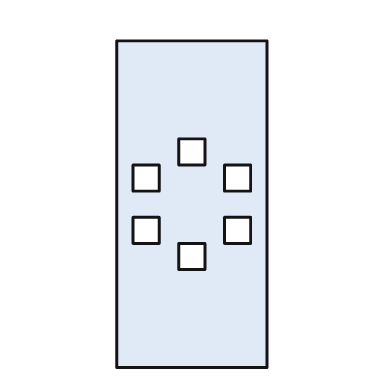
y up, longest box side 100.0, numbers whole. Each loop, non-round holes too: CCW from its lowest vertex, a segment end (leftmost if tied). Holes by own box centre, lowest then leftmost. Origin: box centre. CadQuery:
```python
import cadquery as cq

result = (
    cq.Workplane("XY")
    .moveTo(-23.0, -50.0)
    .lineTo(23.0, -50.0)
    .lineTo(23.0, 50.0)
    .lineTo(-23.0, 50.0)
    .close()
    .moveTo(-4.0, -20.0)
    .lineTo(4.0, -20.0)
    .lineTo(4.0, -12.0)
    .lineTo(-4.0, -12.0)
    .close()
    .moveTo(-18.0, -12.0)
    .lineTo(-10.0, -12.0)
    .lineTo(-10.0, -4.0)
    .lineTo(-18.0, -4.0)
    .close()
    .moveTo(10.0, -12.0)
    .lineTo(18.0, -12.0)
    .lineTo(18.0, -4.0)
    .lineTo(10.0, -4.0)
    .close()
    .moveTo(-18.0, 4.0)
    .lineTo(-10.0, 4.0)
    .lineTo(-10.0, 12.0)
    .lineTo(-18.0, 12.0)
    .close()
    .moveTo(10.0, 4.0)
    .lineTo(18.0, 4.0)
    .lineTo(18.0, 12.0)
    .lineTo(10.0, 12.0)
    .close()
    .moveTo(-4.0, 12.0)
    .lineTo(4.0, 12.0)
    .lineTo(4.0, 20.0)
    .lineTo(-4.0, 20.0)
    .close()
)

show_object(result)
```